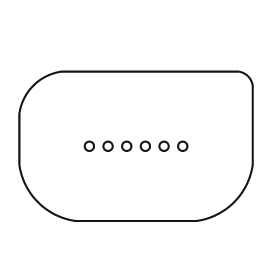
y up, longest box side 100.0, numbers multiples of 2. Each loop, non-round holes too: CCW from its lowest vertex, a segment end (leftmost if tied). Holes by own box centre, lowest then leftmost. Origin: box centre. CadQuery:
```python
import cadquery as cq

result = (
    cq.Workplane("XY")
    .moveTo(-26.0, -32.0)
    .lineTo(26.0, -32.0)
    .threePointArc((42.0, -24.0), (50.0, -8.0))
    .lineTo(50.0, 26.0)
    .threePointArc((48.0, 30.0), (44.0, 32.0))
    .lineTo(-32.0, 32.0)
    .threePointArc((-44.0, 26.0), (-50.0, 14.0))
    .lineTo(-50.0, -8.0)
    .threePointArc((-42.0, -24.0), (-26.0, -32.0))
    .close()
    .moveTo(-20.0, 0.0)
    .circle(2.0)
    .moveTo(-12.0, 0.0)
    .circle(2.0)
    .moveTo(-4.0, 0.0)
    .circle(2.0)
    .moveTo(4.0, 0.0)
    .circle(2.0)
    .moveTo(12.0, 0.0)
    .circle(2.0)
    .moveTo(20.0, 0.0)
    .circle(2.0)
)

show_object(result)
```